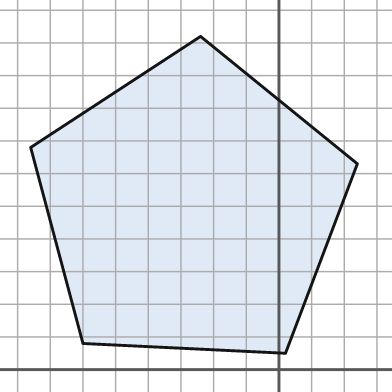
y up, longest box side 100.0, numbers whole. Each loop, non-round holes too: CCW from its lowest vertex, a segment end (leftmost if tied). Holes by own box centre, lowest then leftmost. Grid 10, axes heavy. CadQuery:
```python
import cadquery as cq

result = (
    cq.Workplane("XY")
    .moveTo(2.0, 5.0)
    .lineTo(24.0, 63.0)
    .lineTo(-24.0, 102.0)
    .lineTo(-76.0, 68.0)
    .lineTo(-60.0, 8.0)
    .close()
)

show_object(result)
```